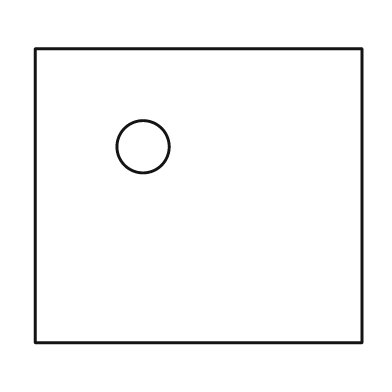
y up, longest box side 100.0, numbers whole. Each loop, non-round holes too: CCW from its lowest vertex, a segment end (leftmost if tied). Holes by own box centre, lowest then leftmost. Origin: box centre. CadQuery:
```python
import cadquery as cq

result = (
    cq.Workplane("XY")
    .moveTo(-50.0, -45.0)
    .lineTo(50.0, -45.0)
    .lineTo(50.0, 45.0)
    .lineTo(-50.0, 45.0)
    .close()
    .moveTo(-17.0, 15.0)
    .circle(8.0)
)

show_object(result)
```